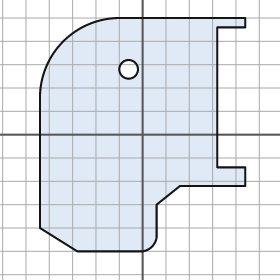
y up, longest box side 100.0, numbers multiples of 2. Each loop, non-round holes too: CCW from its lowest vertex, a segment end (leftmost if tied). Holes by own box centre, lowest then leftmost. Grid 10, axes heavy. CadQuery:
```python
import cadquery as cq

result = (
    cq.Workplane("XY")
    .moveTo(-28.0, -50.0)
    .lineTo(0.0, -50.0)
    .threePointArc((4.0, -48.0), (6.0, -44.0))
    .lineTo(6.0, -30.0)
    .lineTo(16.0, -22.0)
    .lineTo(44.0, -22.0)
    .lineTo(44.0, -14.0)
    .lineTo(32.0, -14.0)
    .lineTo(32.0, 46.0)
    .lineTo(44.0, 46.0)
    .lineTo(44.0, 50.0)
    .lineTo(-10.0, 50.0)
    .threePointArc((-34.0, 40.0), (-44.0, 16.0))
    .lineTo(-44.0, -40.0)
    .close()
    .moveTo(-6.0, 28.0)
    .circle(4.0)
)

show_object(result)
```